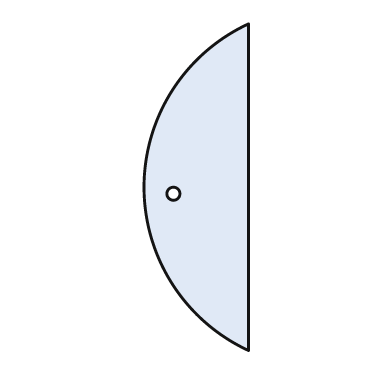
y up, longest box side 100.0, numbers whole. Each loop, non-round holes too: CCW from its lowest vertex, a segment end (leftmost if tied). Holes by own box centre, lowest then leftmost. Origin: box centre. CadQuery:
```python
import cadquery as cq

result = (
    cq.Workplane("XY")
    .moveTo(16.0, -50.0)
    .lineTo(16.0, 50.0)
    .threePointArc((-16.0, 0.0), (16.0, -50.0))
    .close()
    .moveTo(-7.0, -2.0)
    .circle(2.0)
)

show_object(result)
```